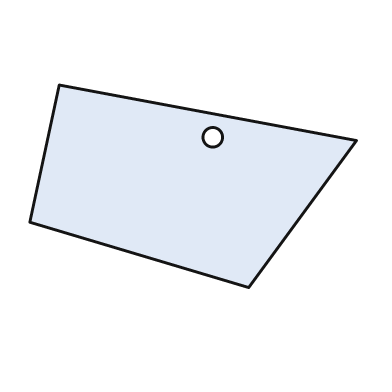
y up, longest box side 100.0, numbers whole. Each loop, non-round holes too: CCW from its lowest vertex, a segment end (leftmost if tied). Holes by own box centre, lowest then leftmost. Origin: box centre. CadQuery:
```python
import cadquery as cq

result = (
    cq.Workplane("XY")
    .moveTo(17.0, -31.0)
    .lineTo(50.0, 14.0)
    .lineTo(-41.0, 31.0)
    .lineTo(-50.0, -11.0)
    .close()
    .moveTo(6.0, 15.0)
    .circle(3.0)
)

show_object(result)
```